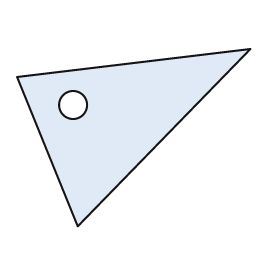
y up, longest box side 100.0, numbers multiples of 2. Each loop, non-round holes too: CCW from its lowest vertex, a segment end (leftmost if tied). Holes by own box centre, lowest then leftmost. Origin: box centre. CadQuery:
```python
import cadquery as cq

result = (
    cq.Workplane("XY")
    .moveTo(-24.0, -38.0)
    .lineTo(50.0, 38.0)
    .lineTo(-50.0, 26.0)
    .close()
    .moveTo(-26.0, 14.0)
    .circle(6.0)
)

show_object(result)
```